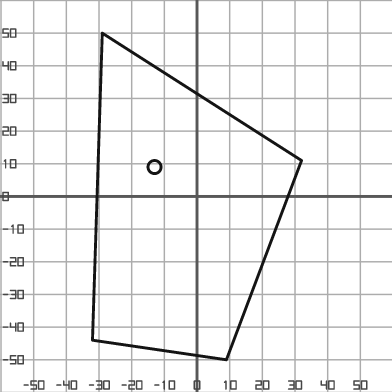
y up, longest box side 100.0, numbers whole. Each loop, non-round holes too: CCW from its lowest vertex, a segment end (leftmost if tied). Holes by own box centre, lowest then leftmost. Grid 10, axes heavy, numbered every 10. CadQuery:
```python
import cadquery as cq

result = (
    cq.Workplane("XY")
    .moveTo(9.0, -50.0)
    .lineTo(32.0, 11.0)
    .lineTo(-29.0, 50.0)
    .lineTo(-32.0, -44.0)
    .close()
    .moveTo(-13.0, 9.0)
    .circle(2.0)
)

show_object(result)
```